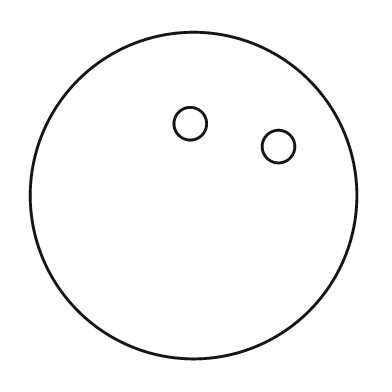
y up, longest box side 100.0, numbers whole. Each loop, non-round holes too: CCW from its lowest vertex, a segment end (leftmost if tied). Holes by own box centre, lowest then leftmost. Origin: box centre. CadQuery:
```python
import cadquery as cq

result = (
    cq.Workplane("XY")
    .moveTo(0.0, 0.0)
    .circle(50.0)
    .moveTo(26.0, 15.0)
    .circle(5.0)
    .moveTo(-1.0, 22.0)
    .circle(5.0)
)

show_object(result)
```